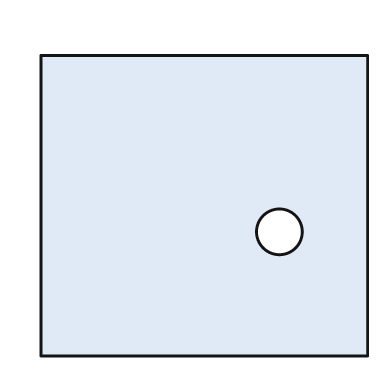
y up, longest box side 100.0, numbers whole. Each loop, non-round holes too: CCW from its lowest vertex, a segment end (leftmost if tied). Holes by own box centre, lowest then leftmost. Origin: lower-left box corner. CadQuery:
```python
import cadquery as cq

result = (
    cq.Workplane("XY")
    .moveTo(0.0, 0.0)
    .lineTo(100.0, 0.0)
    .lineTo(100.0, 92.0)
    .lineTo(0.0, 92.0)
    .close()
    .moveTo(73.0, 38.0)
    .circle(7.0)
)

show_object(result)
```